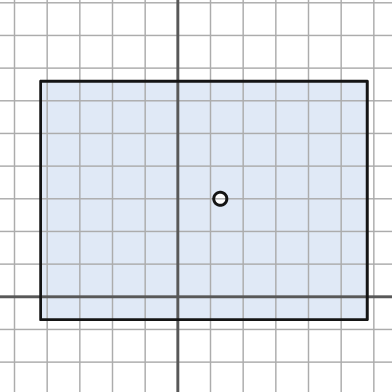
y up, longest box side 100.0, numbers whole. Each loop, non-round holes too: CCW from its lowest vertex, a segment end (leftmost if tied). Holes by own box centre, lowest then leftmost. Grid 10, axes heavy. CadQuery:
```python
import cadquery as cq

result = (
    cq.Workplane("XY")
    .moveTo(-42.0, -7.0)
    .lineTo(58.0, -7.0)
    .lineTo(58.0, 66.0)
    .lineTo(-42.0, 66.0)
    .close()
    .moveTo(13.0, 30.0)
    .circle(2.0)
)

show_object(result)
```